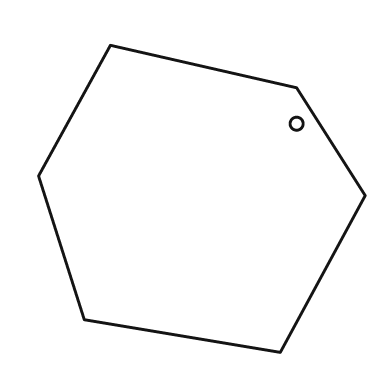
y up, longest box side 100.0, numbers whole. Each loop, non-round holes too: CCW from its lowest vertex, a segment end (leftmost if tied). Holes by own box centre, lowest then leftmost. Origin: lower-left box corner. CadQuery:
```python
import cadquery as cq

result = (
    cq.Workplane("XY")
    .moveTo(74.0, 0.0)
    .lineTo(100.0, 48.0)
    .lineTo(79.0, 81.0)
    .lineTo(22.0, 94.0)
    .lineTo(0.0, 54.0)
    .lineTo(14.0, 10.0)
    .close()
    .moveTo(79.0, 70.0)
    .circle(2.0)
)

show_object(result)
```